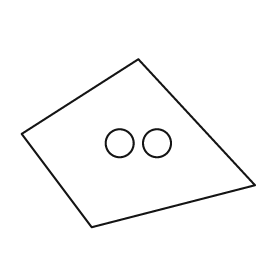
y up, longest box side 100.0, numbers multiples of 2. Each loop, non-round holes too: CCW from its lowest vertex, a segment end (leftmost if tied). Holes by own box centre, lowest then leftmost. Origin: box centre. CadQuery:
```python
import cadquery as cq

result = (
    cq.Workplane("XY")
    .moveTo(-20.0, -36.0)
    .lineTo(50.0, -18.0)
    .lineTo(0.0, 36.0)
    .lineTo(-50.0, 4.0)
    .close()
    .moveTo(-8.0, 0.0)
    .circle(6.0)
    .moveTo(8.0, 0.0)
    .circle(6.0)
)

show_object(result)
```